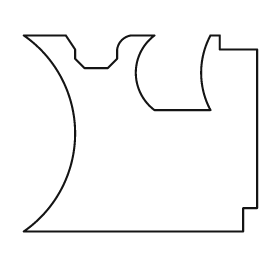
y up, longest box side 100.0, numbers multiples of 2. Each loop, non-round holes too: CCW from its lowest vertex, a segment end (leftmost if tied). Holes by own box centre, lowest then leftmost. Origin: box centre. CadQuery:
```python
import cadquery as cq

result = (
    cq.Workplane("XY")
    .moveTo(-50.0, -42.0)
    .lineTo(44.0, -42.0)
    .lineTo(44.0, -32.0)
    .lineTo(50.0, -32.0)
    .lineTo(50.0, 36.0)
    .lineTo(34.0, 36.0)
    .lineTo(34.0, 42.0)
    .lineTo(30.0, 42.0)
    .threePointArc((26.0, 26.0), (30.0, 10.0))
    .lineTo(6.0, 10.0)
    .threePointArc((-2.0, 26.0), (6.0, 42.0))
    .lineTo(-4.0, 42.0)
    .threePointArc((-8.0, 40.0), (-10.0, 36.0))
    .lineTo(-10.0, 32.0)
    .lineTo(-14.0, 28.0)
    .lineTo(-24.0, 28.0)
    .lineTo(-28.0, 32.0)
    .lineTo(-28.0, 36.0)
    .lineTo(-32.0, 42.0)
    .lineTo(-50.0, 42.0)
    .threePointArc((-28.0, 0.0), (-50.0, -42.0))
    .close()
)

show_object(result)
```